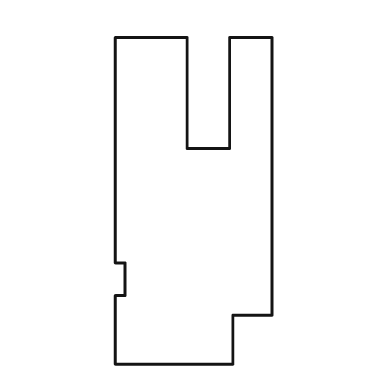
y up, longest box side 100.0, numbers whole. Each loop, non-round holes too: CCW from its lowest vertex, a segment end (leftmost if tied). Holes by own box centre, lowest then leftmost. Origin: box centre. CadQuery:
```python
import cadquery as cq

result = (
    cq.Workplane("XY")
    .moveTo(-24.0, -50.0)
    .lineTo(12.0, -50.0)
    .lineTo(12.0, -35.0)
    .lineTo(24.0, -35.0)
    .lineTo(24.0, 50.0)
    .lineTo(11.0, 50.0)
    .lineTo(11.0, 16.0)
    .lineTo(-2.0, 16.0)
    .lineTo(-2.0, 50.0)
    .lineTo(-24.0, 50.0)
    .lineTo(-24.0, -19.0)
    .lineTo(-21.0, -19.0)
    .lineTo(-21.0, -29.0)
    .lineTo(-24.0, -29.0)
    .close()
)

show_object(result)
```